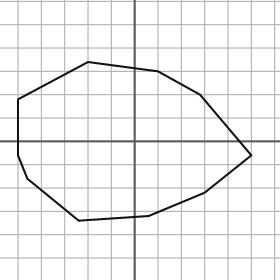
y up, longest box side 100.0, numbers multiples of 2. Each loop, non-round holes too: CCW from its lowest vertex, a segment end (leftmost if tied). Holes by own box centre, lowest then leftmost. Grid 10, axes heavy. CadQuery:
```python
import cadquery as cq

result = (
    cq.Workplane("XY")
    .moveTo(-24.0, -34.0)
    .lineTo(6.0, -32.0)
    .lineTo(30.0, -22.0)
    .lineTo(50.0, -6.0)
    .lineTo(28.0, 20.0)
    .lineTo(10.0, 30.0)
    .lineTo(-20.0, 34.0)
    .lineTo(-50.0, 18.0)
    .lineTo(-50.0, -6.0)
    .lineTo(-46.0, -16.0)
    .close()
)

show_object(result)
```